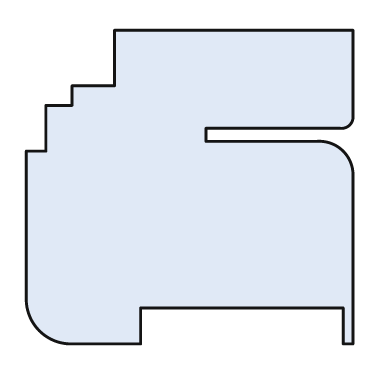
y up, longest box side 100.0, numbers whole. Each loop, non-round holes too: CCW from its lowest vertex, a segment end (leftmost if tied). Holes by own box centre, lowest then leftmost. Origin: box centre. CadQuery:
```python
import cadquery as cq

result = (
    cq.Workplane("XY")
    .moveTo(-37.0, -48.0)
    .lineTo(-15.0, -48.0)
    .lineTo(-15.0, -37.0)
    .lineTo(47.0, -37.0)
    .lineTo(47.0, -48.0)
    .lineTo(50.0, -48.0)
    .lineTo(50.0, 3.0)
    .threePointArc((47.0, 11.0), (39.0, 14.0))
    .lineTo(5.0, 14.0)
    .lineTo(5.0, 18.0)
    .lineTo(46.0, 18.0)
    .threePointArc((49.0, 19.0), (50.0, 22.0))
    .lineTo(50.0, 48.0)
    .lineTo(-23.0, 48.0)
    .lineTo(-23.0, 31.0)
    .lineTo(-36.0, 31.0)
    .lineTo(-36.0, 25.0)
    .lineTo(-44.0, 25.0)
    .lineTo(-44.0, 11.0)
    .lineTo(-50.0, 11.0)
    .lineTo(-50.0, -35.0)
    .threePointArc((-46.0, -44.0), (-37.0, -48.0))
    .close()
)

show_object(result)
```